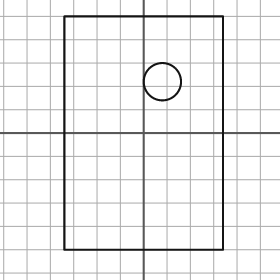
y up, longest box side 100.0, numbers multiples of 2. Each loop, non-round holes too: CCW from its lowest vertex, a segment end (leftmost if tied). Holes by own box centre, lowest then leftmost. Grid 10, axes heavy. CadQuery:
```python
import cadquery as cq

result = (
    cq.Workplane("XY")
    .moveTo(-34.0, -50.0)
    .lineTo(34.0, -50.0)
    .lineTo(34.0, 50.0)
    .lineTo(-34.0, 50.0)
    .close()
    .moveTo(8.0, 22.0)
    .circle(8.0)
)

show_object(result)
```